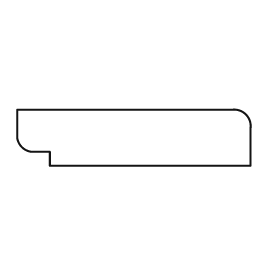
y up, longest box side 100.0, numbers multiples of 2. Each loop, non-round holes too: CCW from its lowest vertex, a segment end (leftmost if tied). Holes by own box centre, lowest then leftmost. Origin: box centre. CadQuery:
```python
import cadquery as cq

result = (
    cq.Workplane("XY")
    .moveTo(-36.0, -12.0)
    .lineTo(50.0, -12.0)
    .lineTo(50.0, 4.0)
    .threePointArc((48.0, 10.0), (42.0, 12.0))
    .lineTo(-50.0, 12.0)
    .lineTo(-50.0, 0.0)
    .threePointArc((-48.0, -4.0), (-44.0, -6.0))
    .lineTo(-36.0, -6.0)
    .close()
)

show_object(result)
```